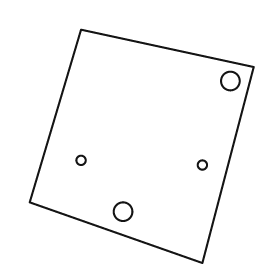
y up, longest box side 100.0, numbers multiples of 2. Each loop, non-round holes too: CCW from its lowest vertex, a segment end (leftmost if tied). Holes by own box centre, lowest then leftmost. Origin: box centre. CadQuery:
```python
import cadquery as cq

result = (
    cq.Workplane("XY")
    .moveTo(26.0, -50.0)
    .lineTo(48.0, 34.0)
    .lineTo(-26.0, 50.0)
    .lineTo(-48.0, -24.0)
    .close()
    .moveTo(-8.0, -28.0)
    .circle(4.0)
    .moveTo(26.0, -8.0)
    .circle(2.0)
    .moveTo(-26.0, -6.0)
    .circle(2.0)
    .moveTo(38.0, 28.0)
    .circle(4.0)
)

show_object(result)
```